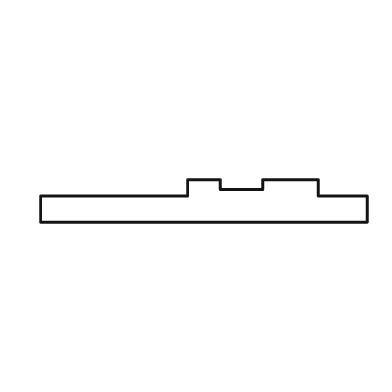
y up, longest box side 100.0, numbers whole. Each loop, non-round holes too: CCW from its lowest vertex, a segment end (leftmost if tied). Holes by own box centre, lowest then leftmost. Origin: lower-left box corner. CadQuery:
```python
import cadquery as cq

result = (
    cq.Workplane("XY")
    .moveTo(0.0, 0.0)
    .lineTo(100.0, 0.0)
    .lineTo(100.0, 8.0)
    .lineTo(85.0, 8.0)
    .lineTo(85.0, 13.0)
    .lineTo(68.0, 13.0)
    .lineTo(68.0, 10.0)
    .lineTo(55.0, 10.0)
    .lineTo(55.0, 13.0)
    .lineTo(45.0, 13.0)
    .lineTo(45.0, 8.0)
    .lineTo(0.0, 8.0)
    .close()
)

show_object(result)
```